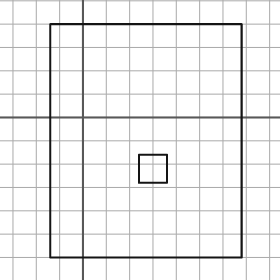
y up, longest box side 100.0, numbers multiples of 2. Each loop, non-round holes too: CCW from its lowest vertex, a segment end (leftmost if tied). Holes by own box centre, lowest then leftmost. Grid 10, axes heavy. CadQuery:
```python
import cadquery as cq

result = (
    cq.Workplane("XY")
    .moveTo(-14.0, -60.0)
    .lineTo(68.0, -60.0)
    .lineTo(68.0, 40.0)
    .lineTo(-14.0, 40.0)
    .close()
    .moveTo(24.0, -28.0)
    .lineTo(36.0, -28.0)
    .lineTo(36.0, -16.0)
    .lineTo(24.0, -16.0)
    .close()
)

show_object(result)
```